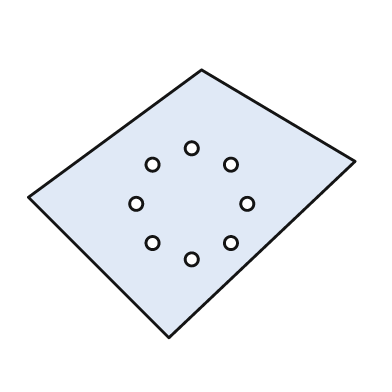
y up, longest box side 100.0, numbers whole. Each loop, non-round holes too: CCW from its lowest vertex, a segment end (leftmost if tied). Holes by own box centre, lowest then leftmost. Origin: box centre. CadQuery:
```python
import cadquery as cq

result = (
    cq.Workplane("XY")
    .moveTo(-7.0, -41.0)
    .lineTo(50.0, 13.0)
    .lineTo(3.0, 41.0)
    .lineTo(-50.0, 2.0)
    .close()
    .moveTo(0.0, -17.0)
    .circle(2.0)
    .moveTo(-12.0, -12.0)
    .circle(2.0)
    .moveTo(12.0, -12.0)
    .circle(2.0)
    .moveTo(-17.0, 0.0)
    .circle(2.0)
    .moveTo(17.0, 0.0)
    .circle(2.0)
    .moveTo(-12.0, 12.0)
    .circle(2.0)
    .moveTo(12.0, 12.0)
    .circle(2.0)
    .moveTo(0.0, 17.0)
    .circle(2.0)
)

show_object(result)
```